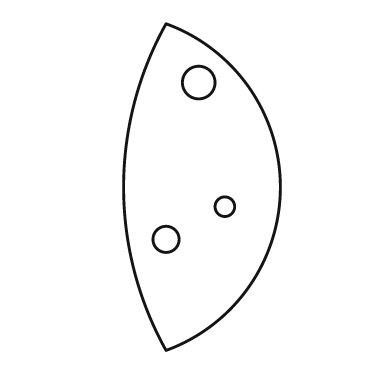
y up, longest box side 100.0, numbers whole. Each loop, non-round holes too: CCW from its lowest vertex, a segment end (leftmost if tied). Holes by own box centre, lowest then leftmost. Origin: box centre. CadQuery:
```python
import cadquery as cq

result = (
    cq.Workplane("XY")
    .moveTo(-11.0, -50.0)
    .threePointArc((24.0, 0.0), (-11.0, 50.0))
    .threePointArc((-24.0, 0.0), (-11.0, -50.0))
    .close()
    .moveTo(-11.0, -16.0)
    .circle(4.0)
    .moveTo(7.0, -6.0)
    .circle(3.0)
    .moveTo(-1.0, 32.0)
    .circle(5.0)
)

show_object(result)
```